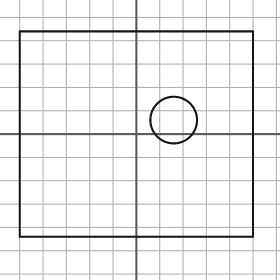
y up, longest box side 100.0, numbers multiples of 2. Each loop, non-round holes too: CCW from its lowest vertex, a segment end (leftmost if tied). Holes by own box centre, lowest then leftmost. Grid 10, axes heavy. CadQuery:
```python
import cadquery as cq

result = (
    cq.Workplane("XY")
    .moveTo(-50.0, -44.0)
    .lineTo(50.0, -44.0)
    .lineTo(50.0, 44.0)
    .lineTo(-50.0, 44.0)
    .close()
    .moveTo(16.0, 6.0)
    .circle(10.0)
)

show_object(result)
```